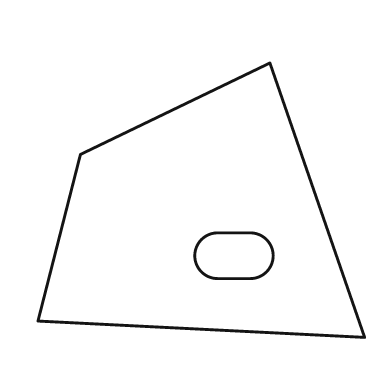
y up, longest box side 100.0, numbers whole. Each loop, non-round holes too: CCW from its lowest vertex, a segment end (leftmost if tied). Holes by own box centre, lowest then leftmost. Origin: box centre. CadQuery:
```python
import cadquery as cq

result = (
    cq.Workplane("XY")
    .moveTo(50.0, -42.0)
    .lineTo(21.0, 42.0)
    .lineTo(-37.0, 14.0)
    .lineTo(-50.0, -37.0)
    .close()
    .moveTo(5.0, -24.0)
    .lineTo(15.0, -24.0)
    .threePointArc((22.0, -17.0), (15.0, -10.0))
    .lineTo(5.0, -10.0)
    .threePointArc((-2.0, -17.0), (5.0, -24.0))
    .close()
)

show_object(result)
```